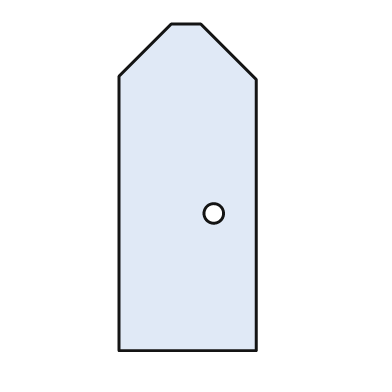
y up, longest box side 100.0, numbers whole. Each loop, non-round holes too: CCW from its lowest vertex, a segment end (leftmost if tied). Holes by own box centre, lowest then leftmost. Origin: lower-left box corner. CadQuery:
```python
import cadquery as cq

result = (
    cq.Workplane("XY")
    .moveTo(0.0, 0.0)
    .lineTo(42.0, 0.0)
    .lineTo(42.0, 83.0)
    .lineTo(25.0, 100.0)
    .lineTo(16.0, 100.0)
    .lineTo(0.0, 84.0)
    .close()
    .moveTo(29.0, 42.0)
    .circle(3.0)
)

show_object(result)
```